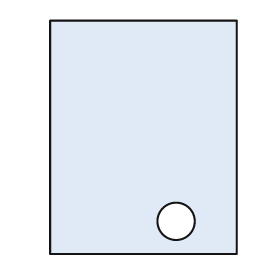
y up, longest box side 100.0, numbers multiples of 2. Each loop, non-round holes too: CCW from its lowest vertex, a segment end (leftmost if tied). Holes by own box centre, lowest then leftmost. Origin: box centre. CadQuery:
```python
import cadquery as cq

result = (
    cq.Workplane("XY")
    .moveTo(-40.0, -50.0)
    .lineTo(40.0, -50.0)
    .lineTo(40.0, 50.0)
    .lineTo(-40.0, 50.0)
    .close()
    .moveTo(14.0, -36.0)
    .circle(8.0)
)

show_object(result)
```